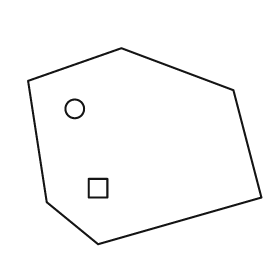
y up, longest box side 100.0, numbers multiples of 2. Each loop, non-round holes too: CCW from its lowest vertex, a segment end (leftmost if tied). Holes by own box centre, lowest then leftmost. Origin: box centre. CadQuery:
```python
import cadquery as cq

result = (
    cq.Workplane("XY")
    .moveTo(-20.0, -42.0)
    .lineTo(50.0, -22.0)
    .lineTo(38.0, 24.0)
    .lineTo(-10.0, 42.0)
    .lineTo(-50.0, 28.0)
    .lineTo(-42.0, -24.0)
    .close()
    .moveTo(-24.0, -22.0)
    .lineTo(-16.0, -22.0)
    .lineTo(-16.0, -14.0)
    .lineTo(-24.0, -14.0)
    .close()
    .moveTo(-30.0, 16.0)
    .circle(4.0)
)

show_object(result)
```